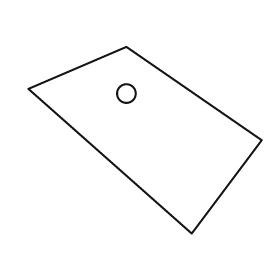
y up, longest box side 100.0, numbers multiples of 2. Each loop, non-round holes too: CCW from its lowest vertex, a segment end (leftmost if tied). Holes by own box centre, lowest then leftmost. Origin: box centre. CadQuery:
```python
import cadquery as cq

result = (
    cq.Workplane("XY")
    .moveTo(20.0, -40.0)
    .lineTo(50.0, 0.0)
    .lineTo(-8.0, 40.0)
    .lineTo(-50.0, 22.0)
    .close()
    .moveTo(-8.0, 20.0)
    .circle(4.0)
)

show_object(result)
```